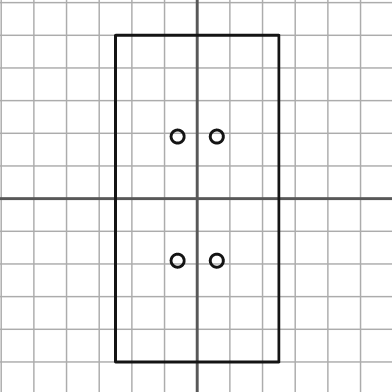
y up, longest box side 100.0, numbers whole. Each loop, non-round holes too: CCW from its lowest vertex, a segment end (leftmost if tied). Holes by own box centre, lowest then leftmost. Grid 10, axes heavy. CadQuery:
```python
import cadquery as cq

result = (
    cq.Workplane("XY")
    .moveTo(-25.0, -50.0)
    .lineTo(25.0, -50.0)
    .lineTo(25.0, 50.0)
    .lineTo(-25.0, 50.0)
    .close()
    .moveTo(-6.0, -19.0)
    .circle(2.0)
    .moveTo(6.0, -19.0)
    .circle(2.0)
    .moveTo(-6.0, 19.0)
    .circle(2.0)
    .moveTo(6.0, 19.0)
    .circle(2.0)
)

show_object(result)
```